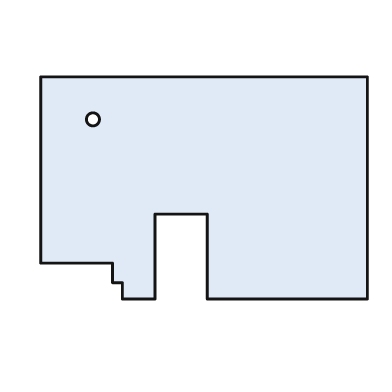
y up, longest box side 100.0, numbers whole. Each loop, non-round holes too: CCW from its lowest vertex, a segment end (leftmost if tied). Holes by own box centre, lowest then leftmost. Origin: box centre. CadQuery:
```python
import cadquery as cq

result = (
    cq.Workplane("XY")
    .moveTo(-25.0, -34.0)
    .lineTo(-15.0, -34.0)
    .lineTo(-15.0, -8.0)
    .lineTo(1.0, -8.0)
    .lineTo(1.0, -34.0)
    .lineTo(50.0, -34.0)
    .lineTo(50.0, 34.0)
    .lineTo(-50.0, 34.0)
    .lineTo(-50.0, -23.0)
    .lineTo(-28.0, -23.0)
    .lineTo(-28.0, -29.0)
    .lineTo(-25.0, -29.0)
    .close()
    .moveTo(-34.0, 21.0)
    .circle(2.0)
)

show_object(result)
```